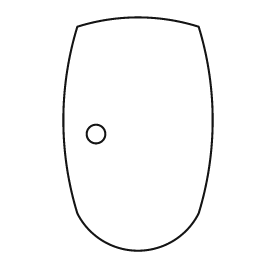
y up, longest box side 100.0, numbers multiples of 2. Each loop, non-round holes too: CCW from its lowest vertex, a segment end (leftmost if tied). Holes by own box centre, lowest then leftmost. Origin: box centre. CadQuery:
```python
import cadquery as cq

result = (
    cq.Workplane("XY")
    .moveTo(-26.0, -34.0)
    .threePointArc((0.0, -50.0), (26.0, -34.0))
    .threePointArc((32.0, 6.0), (26.0, 46.0))
    .threePointArc((0.0, 50.0), (-26.0, 46.0))
    .threePointArc((-32.0, 6.0), (-26.0, -34.0))
    .close()
    .moveTo(-18.0, 0.0)
    .circle(4.0)
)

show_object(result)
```